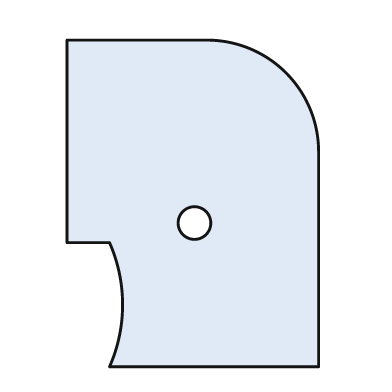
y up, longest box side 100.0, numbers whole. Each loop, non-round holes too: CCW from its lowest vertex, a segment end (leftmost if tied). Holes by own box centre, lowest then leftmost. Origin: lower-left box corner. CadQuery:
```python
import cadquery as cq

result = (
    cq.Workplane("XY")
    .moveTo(13.0, 0.0)
    .lineTo(77.0, 0.0)
    .lineTo(77.0, 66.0)
    .threePointArc((67.0, 90.0), (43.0, 100.0))
    .lineTo(0.0, 100.0)
    .lineTo(0.0, 38.0)
    .lineTo(13.0, 38.0)
    .threePointArc((17.0, 19.0), (13.0, 0.0))
    .close()
    .moveTo(39.0, 44.0)
    .circle(5.0)
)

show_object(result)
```